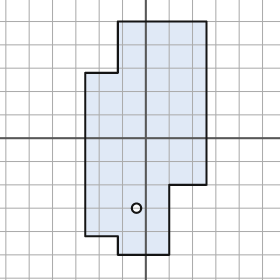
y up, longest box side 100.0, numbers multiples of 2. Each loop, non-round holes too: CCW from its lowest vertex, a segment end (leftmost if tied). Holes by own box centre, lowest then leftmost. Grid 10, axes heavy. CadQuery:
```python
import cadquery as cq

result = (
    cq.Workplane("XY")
    .moveTo(-12.0, -50.0)
    .lineTo(10.0, -50.0)
    .lineTo(10.0, -20.0)
    .lineTo(26.0, -20.0)
    .lineTo(26.0, 50.0)
    .lineTo(-12.0, 50.0)
    .lineTo(-12.0, 28.0)
    .lineTo(-26.0, 28.0)
    .lineTo(-26.0, -42.0)
    .lineTo(-12.0, -42.0)
    .close()
    .moveTo(-4.0, -30.0)
    .circle(2.0)
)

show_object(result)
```